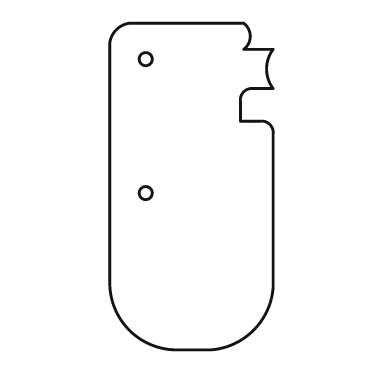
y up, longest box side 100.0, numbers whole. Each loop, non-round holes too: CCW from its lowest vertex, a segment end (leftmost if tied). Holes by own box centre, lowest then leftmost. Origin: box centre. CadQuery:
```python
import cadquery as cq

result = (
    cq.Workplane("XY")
    .moveTo(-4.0, -50.0)
    .lineTo(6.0, -50.0)
    .threePointArc((19.0, -44.0), (25.0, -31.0))
    .lineTo(25.0, 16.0)
    .threePointArc((24.0, 19.0), (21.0, 20.0))
    .lineTo(15.0, 20.0)
    .lineTo(15.0, 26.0)
    .threePointArc((16.0, 29.0), (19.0, 30.0))
    .lineTo(25.0, 30.0)
    .threePointArc((23.0, 36.0), (25.0, 42.0))
    .lineTo(16.0, 42.0)
    .threePointArc((18.0, 46.0), (16.0, 50.0))
    .lineTo(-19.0, 50.0)
    .threePointArc((-23.0, 48.0), (-25.0, 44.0))
    .lineTo(-25.0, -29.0)
    .threePointArc((-19.0, -44.0), (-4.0, -50.0))
    .close()
    .moveTo(-14.0, -2.0)
    .circle(2.0)
    .moveTo(-14.0, 39.0)
    .circle(2.0)
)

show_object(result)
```